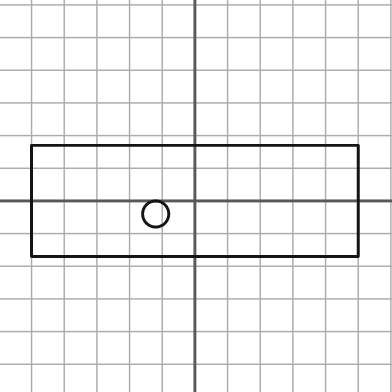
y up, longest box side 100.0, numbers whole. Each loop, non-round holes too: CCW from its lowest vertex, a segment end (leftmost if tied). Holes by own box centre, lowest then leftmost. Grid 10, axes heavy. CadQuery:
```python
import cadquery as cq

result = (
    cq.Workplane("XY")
    .moveTo(-50.0, -17.0)
    .lineTo(50.0, -17.0)
    .lineTo(50.0, 17.0)
    .lineTo(-50.0, 17.0)
    .close()
    .moveTo(-12.0, -4.0)
    .circle(4.0)
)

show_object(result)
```